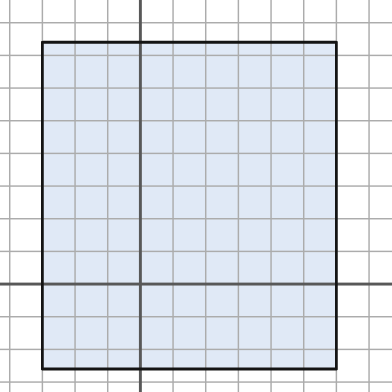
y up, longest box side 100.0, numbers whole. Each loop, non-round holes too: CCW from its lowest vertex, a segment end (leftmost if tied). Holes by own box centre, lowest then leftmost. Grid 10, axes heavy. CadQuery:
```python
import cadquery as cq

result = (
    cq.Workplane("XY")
    .moveTo(-30.0, -26.0)
    .lineTo(60.0, -26.0)
    .lineTo(60.0, 74.0)
    .lineTo(-30.0, 74.0)
    .close()
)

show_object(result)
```